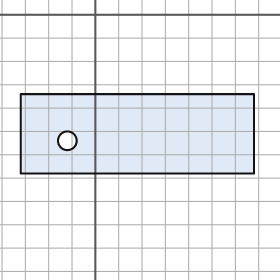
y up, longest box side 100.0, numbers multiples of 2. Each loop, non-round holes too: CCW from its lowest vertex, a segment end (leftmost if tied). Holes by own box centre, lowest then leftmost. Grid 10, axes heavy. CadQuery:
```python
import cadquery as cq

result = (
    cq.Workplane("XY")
    .moveTo(-32.0, -68.0)
    .lineTo(68.0, -68.0)
    .lineTo(68.0, -34.0)
    .lineTo(-32.0, -34.0)
    .close()
    .moveTo(-12.0, -54.0)
    .circle(4.0)
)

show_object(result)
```